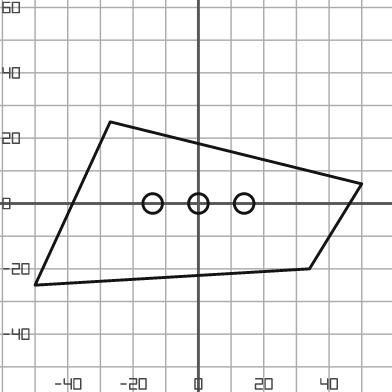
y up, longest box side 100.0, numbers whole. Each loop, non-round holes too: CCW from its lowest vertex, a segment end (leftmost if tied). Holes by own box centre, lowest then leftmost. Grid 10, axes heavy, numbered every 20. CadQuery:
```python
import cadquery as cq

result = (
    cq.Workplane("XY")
    .moveTo(-50.0, -25.0)
    .lineTo(34.0, -20.0)
    .lineTo(50.0, 6.0)
    .lineTo(-27.0, 25.0)
    .close()
    .moveTo(-14.0, 0.0)
    .circle(3.0)
    .moveTo(0.0, 0.0)
    .circle(3.0)
    .moveTo(14.0, 0.0)
    .circle(3.0)
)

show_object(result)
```